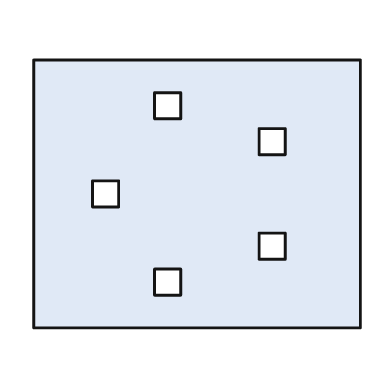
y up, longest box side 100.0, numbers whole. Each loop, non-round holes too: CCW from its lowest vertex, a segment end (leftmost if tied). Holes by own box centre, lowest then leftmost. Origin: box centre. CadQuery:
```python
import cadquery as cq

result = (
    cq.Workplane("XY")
    .moveTo(-50.0, -41.0)
    .lineTo(50.0, -41.0)
    .lineTo(50.0, 41.0)
    .lineTo(-50.0, 41.0)
    .close()
    .moveTo(-13.0, -31.0)
    .lineTo(-5.0, -31.0)
    .lineTo(-5.0, -23.0)
    .lineTo(-13.0, -23.0)
    .close()
    .moveTo(19.0, -20.0)
    .lineTo(27.0, -20.0)
    .lineTo(27.0, -12.0)
    .lineTo(19.0, -12.0)
    .close()
    .moveTo(-32.0, -4.0)
    .lineTo(-24.0, -4.0)
    .lineTo(-24.0, 4.0)
    .lineTo(-32.0, 4.0)
    .close()
    .moveTo(19.0, 12.0)
    .lineTo(27.0, 12.0)
    .lineTo(27.0, 20.0)
    .lineTo(19.0, 20.0)
    .close()
    .moveTo(-13.0, 23.0)
    .lineTo(-5.0, 23.0)
    .lineTo(-5.0, 31.0)
    .lineTo(-13.0, 31.0)
    .close()
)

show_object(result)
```